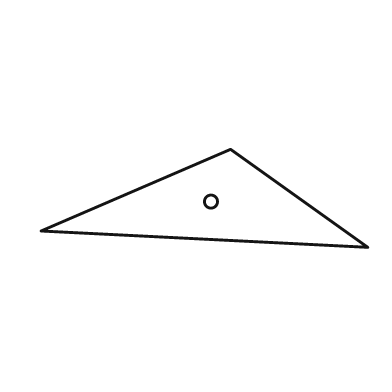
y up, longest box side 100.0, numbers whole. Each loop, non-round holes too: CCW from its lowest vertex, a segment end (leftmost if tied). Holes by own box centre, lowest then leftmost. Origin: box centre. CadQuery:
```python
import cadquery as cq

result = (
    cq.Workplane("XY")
    .moveTo(50.0, -15.0)
    .lineTo(8.0, 15.0)
    .lineTo(-50.0, -10.0)
    .close()
    .moveTo(2.0, -1.0)
    .circle(2.0)
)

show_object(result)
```